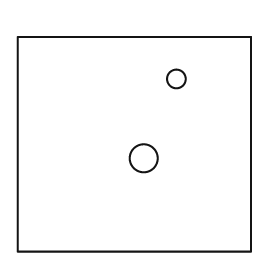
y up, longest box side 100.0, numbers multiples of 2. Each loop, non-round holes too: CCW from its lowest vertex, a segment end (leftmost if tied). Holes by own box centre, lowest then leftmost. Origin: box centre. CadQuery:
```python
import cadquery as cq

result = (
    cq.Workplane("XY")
    .moveTo(-50.0, -46.0)
    .lineTo(50.0, -46.0)
    .lineTo(50.0, 46.0)
    .lineTo(-50.0, 46.0)
    .close()
    .moveTo(4.0, -6.0)
    .circle(6.0)
    .moveTo(18.0, 28.0)
    .circle(4.0)
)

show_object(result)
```